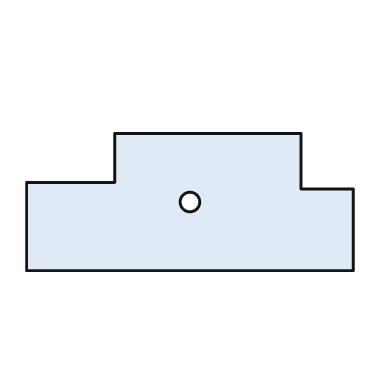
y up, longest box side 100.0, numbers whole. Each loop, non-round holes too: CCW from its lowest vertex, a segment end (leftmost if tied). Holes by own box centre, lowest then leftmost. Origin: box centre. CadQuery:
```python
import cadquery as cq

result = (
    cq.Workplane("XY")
    .moveTo(-50.0, -21.0)
    .lineTo(50.0, -21.0)
    .lineTo(50.0, 4.0)
    .lineTo(34.0, 4.0)
    .lineTo(34.0, 21.0)
    .lineTo(-23.0, 21.0)
    .lineTo(-23.0, 6.0)
    .lineTo(-50.0, 6.0)
    .close()
    .moveTo(0.0, 0.0)
    .circle(3.0)
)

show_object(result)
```